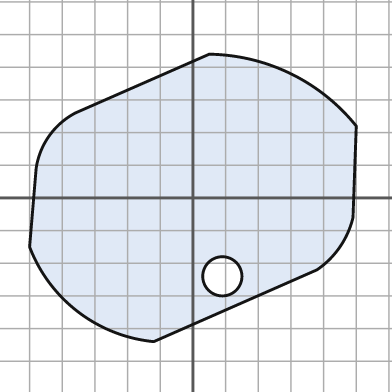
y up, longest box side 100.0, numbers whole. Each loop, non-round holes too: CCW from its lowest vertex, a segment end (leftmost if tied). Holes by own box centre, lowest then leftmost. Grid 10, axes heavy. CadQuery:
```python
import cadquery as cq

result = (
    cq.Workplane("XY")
    .moveTo(-12.0, -44.0)
    .lineTo(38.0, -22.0)
    .threePointArc((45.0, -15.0), (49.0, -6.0))
    .lineTo(50.0, 22.0)
    .threePointArc((30.0, 38.0), (5.0, 44.0))
    .lineTo(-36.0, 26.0)
    .threePointArc((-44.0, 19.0), (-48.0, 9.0))
    .lineTo(-50.0, -15.0)
    .threePointArc((-35.0, -35.0), (-12.0, -44.0))
    .close()
    .moveTo(9.0, -24.0)
    .circle(6.0)
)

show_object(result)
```